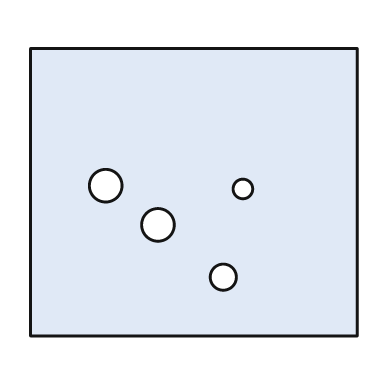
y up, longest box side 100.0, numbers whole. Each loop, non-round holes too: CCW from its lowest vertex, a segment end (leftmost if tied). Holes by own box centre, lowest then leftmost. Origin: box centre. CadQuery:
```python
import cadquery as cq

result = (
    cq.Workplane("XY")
    .moveTo(-50.0, -44.0)
    .lineTo(50.0, -44.0)
    .lineTo(50.0, 44.0)
    .lineTo(-50.0, 44.0)
    .close()
    .moveTo(9.0, -26.0)
    .circle(4.0)
    .moveTo(-11.0, -10.0)
    .circle(5.0)
    .moveTo(15.0, 1.0)
    .circle(3.0)
    .moveTo(-27.0, 2.0)
    .circle(5.0)
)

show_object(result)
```